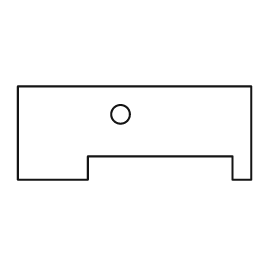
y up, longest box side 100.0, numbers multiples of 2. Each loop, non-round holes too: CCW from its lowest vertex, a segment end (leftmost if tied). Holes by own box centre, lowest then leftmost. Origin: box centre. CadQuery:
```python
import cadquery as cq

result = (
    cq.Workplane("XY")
    .moveTo(-50.0, -20.0)
    .lineTo(-20.0, -20.0)
    .lineTo(-20.0, -10.0)
    .lineTo(42.0, -10.0)
    .lineTo(42.0, -20.0)
    .lineTo(50.0, -20.0)
    .lineTo(50.0, 20.0)
    .lineTo(-50.0, 20.0)
    .close()
    .moveTo(-6.0, 8.0)
    .circle(4.0)
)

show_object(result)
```